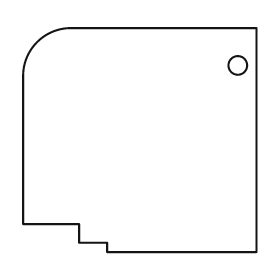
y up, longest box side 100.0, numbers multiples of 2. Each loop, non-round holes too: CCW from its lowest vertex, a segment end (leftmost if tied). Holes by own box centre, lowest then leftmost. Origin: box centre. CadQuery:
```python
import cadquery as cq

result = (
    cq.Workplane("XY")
    .moveTo(-14.0, -48.0)
    .lineTo(50.0, -48.0)
    .lineTo(50.0, 48.0)
    .lineTo(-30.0, 48.0)
    .threePointArc((-44.0, 42.0), (-50.0, 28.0))
    .lineTo(-50.0, -36.0)
    .lineTo(-26.0, -36.0)
    .lineTo(-26.0, -44.0)
    .lineTo(-14.0, -44.0)
    .close()
    .moveTo(42.0, 32.0)
    .circle(4.0)
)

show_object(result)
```